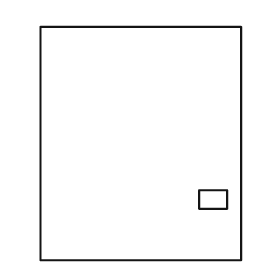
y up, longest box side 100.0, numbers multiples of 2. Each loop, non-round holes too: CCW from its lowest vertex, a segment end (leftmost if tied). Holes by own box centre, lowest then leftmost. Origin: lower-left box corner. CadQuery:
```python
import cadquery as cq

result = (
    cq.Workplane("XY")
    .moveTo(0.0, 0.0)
    .lineTo(86.0, 0.0)
    .lineTo(86.0, 100.0)
    .lineTo(0.0, 100.0)
    .close()
    .moveTo(68.0, 22.0)
    .lineTo(80.0, 22.0)
    .lineTo(80.0, 30.0)
    .lineTo(68.0, 30.0)
    .close()
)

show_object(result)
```